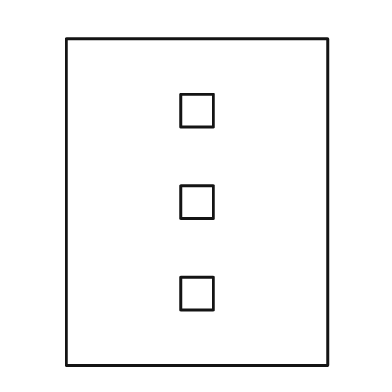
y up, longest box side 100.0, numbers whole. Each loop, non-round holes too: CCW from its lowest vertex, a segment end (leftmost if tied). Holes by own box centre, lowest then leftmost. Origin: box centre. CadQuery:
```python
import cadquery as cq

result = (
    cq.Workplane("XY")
    .moveTo(-40.0, -50.0)
    .lineTo(40.0, -50.0)
    .lineTo(40.0, 50.0)
    .lineTo(-40.0, 50.0)
    .close()
    .moveTo(-5.0, -33.0)
    .lineTo(5.0, -33.0)
    .lineTo(5.0, -23.0)
    .lineTo(-5.0, -23.0)
    .close()
    .moveTo(-5.0, -5.0)
    .lineTo(5.0, -5.0)
    .lineTo(5.0, 5.0)
    .lineTo(-5.0, 5.0)
    .close()
    .moveTo(-5.0, 23.0)
    .lineTo(5.0, 23.0)
    .lineTo(5.0, 33.0)
    .lineTo(-5.0, 33.0)
    .close()
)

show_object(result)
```